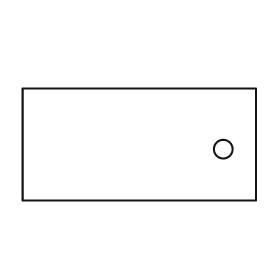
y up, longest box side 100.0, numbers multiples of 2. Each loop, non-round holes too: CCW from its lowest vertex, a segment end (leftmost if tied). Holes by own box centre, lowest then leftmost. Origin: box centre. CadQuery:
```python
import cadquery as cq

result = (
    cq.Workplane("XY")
    .moveTo(-50.0, -24.0)
    .lineTo(50.0, -24.0)
    .lineTo(50.0, 24.0)
    .lineTo(-50.0, 24.0)
    .close()
    .moveTo(36.0, -2.0)
    .circle(4.0)
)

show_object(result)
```